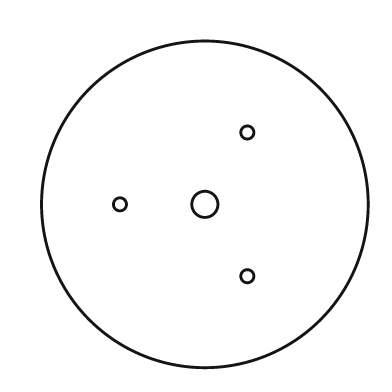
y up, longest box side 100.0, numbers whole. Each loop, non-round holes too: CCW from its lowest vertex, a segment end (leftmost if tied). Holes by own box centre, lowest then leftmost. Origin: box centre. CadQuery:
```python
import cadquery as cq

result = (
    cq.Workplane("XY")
    .moveTo(0.0, 0.0)
    .circle(50.0)
    .moveTo(13.0, -22.0)
    .circle(2.0)
    .moveTo(-26.0, 0.0)
    .circle(2.0)
    .moveTo(0.0, 0.0)
    .circle(4.0)
    .moveTo(13.0, 22.0)
    .circle(2.0)
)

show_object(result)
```